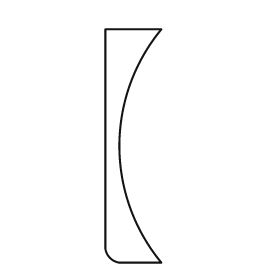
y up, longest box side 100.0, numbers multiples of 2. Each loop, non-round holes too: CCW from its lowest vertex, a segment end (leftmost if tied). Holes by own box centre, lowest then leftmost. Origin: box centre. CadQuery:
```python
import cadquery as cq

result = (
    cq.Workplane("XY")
    .moveTo(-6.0, -50.0)
    .lineTo(12.0, -50.0)
    .threePointArc((-6.0, 0.0), (12.0, 50.0))
    .lineTo(-12.0, 50.0)
    .lineTo(-12.0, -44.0)
    .threePointArc((-10.0, -48.0), (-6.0, -50.0))
    .close()
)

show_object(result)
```